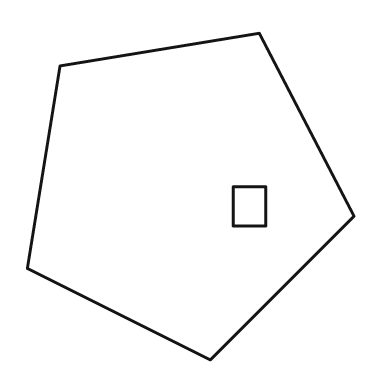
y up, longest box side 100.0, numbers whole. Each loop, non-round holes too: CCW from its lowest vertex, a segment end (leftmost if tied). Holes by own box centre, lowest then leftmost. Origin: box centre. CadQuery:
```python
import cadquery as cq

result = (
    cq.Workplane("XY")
    .moveTo(6.0, -50.0)
    .lineTo(50.0, -6.0)
    .lineTo(21.0, 50.0)
    .lineTo(-40.0, 40.0)
    .lineTo(-50.0, -22.0)
    .close()
    .moveTo(13.0, -9.0)
    .lineTo(23.0, -9.0)
    .lineTo(23.0, 3.0)
    .lineTo(13.0, 3.0)
    .close()
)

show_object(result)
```